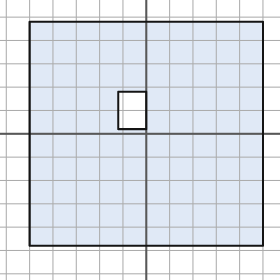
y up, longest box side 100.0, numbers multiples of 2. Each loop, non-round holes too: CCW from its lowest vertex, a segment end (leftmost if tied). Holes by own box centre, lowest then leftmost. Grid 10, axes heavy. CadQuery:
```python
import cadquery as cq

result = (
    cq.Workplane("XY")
    .moveTo(-50.0, -48.0)
    .lineTo(50.0, -48.0)
    .lineTo(50.0, 48.0)
    .lineTo(-50.0, 48.0)
    .close()
    .moveTo(-12.0, 2.0)
    .lineTo(0.0, 2.0)
    .lineTo(0.0, 18.0)
    .lineTo(-12.0, 18.0)
    .close()
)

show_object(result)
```